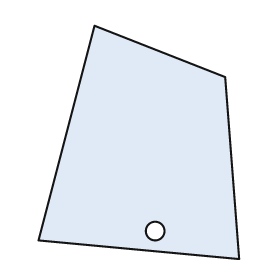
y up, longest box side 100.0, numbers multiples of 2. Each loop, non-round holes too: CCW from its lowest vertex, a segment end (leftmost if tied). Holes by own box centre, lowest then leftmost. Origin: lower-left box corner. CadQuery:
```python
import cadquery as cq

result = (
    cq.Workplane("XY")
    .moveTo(86.0, 0.0)
    .lineTo(80.0, 78.0)
    .lineTo(24.0, 100.0)
    .lineTo(0.0, 8.0)
    .close()
    .moveTo(50.0, 12.0)
    .circle(4.0)
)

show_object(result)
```